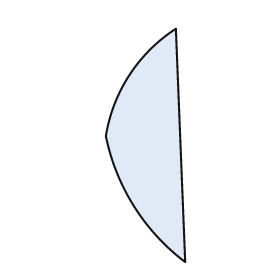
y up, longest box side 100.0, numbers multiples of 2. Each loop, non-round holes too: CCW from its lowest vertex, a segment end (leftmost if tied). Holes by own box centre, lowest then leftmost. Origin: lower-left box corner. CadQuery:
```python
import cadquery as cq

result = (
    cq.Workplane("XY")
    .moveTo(34.0, 0.0)
    .lineTo(30.0, 100.0)
    .threePointArc((10.0, 80.0), (0.0, 54.0))
    .threePointArc((12.0, 24.0), (34.0, 0.0))
    .close()
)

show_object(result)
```